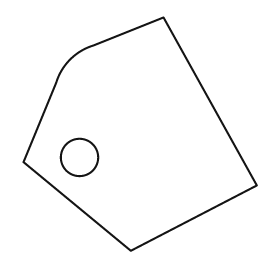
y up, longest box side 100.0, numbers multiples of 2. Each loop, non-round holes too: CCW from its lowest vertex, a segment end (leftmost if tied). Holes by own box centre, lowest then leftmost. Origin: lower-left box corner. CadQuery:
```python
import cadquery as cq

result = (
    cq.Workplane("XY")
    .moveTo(46.0, 0.0)
    .lineTo(100.0, 28.0)
    .lineTo(60.0, 100.0)
    .lineTo(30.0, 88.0)
    .threePointArc((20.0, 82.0), (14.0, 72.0))
    .lineTo(0.0, 38.0)
    .close()
    .moveTo(24.0, 40.0)
    .circle(8.0)
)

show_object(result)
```